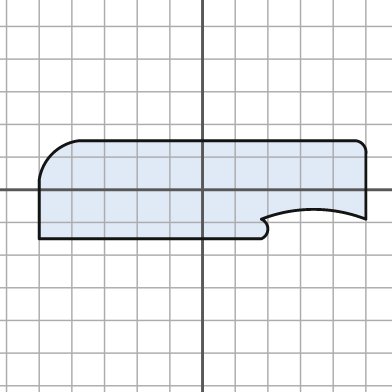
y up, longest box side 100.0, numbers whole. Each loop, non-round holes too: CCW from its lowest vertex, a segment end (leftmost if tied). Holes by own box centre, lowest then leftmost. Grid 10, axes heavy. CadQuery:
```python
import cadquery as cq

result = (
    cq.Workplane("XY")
    .moveTo(-50.0, -15.0)
    .lineTo(18.0, -15.0)
    .threePointArc((20.0, -12.0), (18.0, -9.0))
    .threePointArc((34.0, -6.0), (50.0, -9.0))
    .lineTo(50.0, 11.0)
    .threePointArc((49.0, 14.0), (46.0, 15.0))
    .lineTo(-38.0, 15.0)
    .threePointArc((-46.0, 11.0), (-50.0, 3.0))
    .close()
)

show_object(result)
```